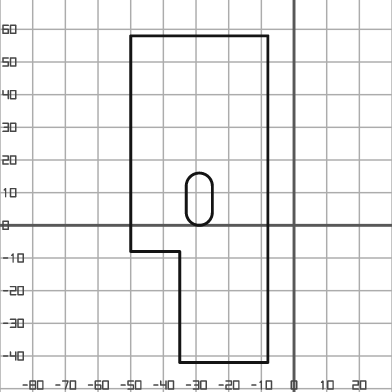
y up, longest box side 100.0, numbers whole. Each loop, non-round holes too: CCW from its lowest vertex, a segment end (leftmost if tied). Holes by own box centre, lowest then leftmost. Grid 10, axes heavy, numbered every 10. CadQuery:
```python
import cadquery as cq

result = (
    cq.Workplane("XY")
    .moveTo(-35.0, -42.0)
    .lineTo(-8.0, -42.0)
    .lineTo(-8.0, 58.0)
    .lineTo(-50.0, 58.0)
    .lineTo(-50.0, -8.0)
    .lineTo(-35.0, -8.0)
    .close()
    .moveTo(-33.0, 4.0)
    .threePointArc((-29.0, 0.0), (-25.0, 4.0))
    .lineTo(-25.0, 12.0)
    .threePointArc((-29.0, 16.0), (-33.0, 12.0))
    .close()
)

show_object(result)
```